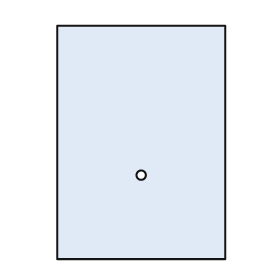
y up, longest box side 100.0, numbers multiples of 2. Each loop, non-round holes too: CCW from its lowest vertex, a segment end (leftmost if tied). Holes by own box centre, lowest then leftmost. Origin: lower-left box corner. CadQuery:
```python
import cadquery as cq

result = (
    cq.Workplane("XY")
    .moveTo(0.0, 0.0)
    .lineTo(72.0, 0.0)
    .lineTo(72.0, 100.0)
    .lineTo(0.0, 100.0)
    .close()
    .moveTo(36.0, 36.0)
    .circle(2.0)
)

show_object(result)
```